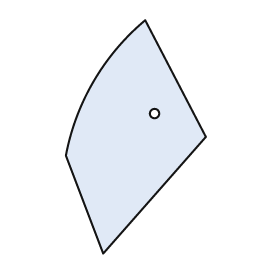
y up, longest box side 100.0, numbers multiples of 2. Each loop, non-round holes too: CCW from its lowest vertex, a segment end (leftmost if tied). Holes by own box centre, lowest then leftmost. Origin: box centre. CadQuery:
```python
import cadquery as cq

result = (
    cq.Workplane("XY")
    .moveTo(-14.0, -50.0)
    .lineTo(30.0, 0.0)
    .lineTo(4.0, 50.0)
    .threePointArc((-18.0, 24.0), (-30.0, -8.0))
    .close()
    .moveTo(8.0, 10.0)
    .circle(2.0)
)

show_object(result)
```